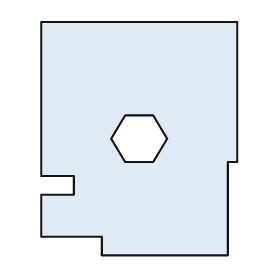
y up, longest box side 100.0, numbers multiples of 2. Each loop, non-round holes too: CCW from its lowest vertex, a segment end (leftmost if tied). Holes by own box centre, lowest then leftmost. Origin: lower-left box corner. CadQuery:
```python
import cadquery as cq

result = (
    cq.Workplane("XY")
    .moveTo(26.0, 0.0)
    .lineTo(80.0, 0.0)
    .lineTo(80.0, 40.0)
    .lineTo(84.0, 40.0)
    .lineTo(84.0, 100.0)
    .lineTo(0.0, 100.0)
    .lineTo(0.0, 34.0)
    .lineTo(14.0, 34.0)
    .lineTo(14.0, 26.0)
    .lineTo(0.0, 26.0)
    .lineTo(0.0, 8.0)
    .lineTo(26.0, 8.0)
    .close()
    .moveTo(36.0, 40.0)
    .lineTo(48.0, 40.0)
    .lineTo(54.0, 50.0)
    .lineTo(48.0, 60.0)
    .lineTo(36.0, 60.0)
    .lineTo(30.0, 50.0)
    .close()
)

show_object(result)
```